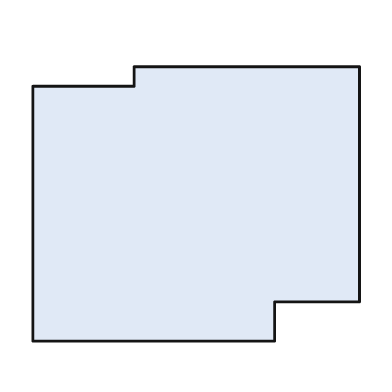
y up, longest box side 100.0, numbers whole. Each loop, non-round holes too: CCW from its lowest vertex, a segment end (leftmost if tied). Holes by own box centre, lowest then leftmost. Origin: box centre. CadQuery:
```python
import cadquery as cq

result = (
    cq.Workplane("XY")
    .moveTo(-50.0, -42.0)
    .lineTo(24.0, -42.0)
    .lineTo(24.0, -30.0)
    .lineTo(50.0, -30.0)
    .lineTo(50.0, 42.0)
    .lineTo(-19.0, 42.0)
    .lineTo(-19.0, 36.0)
    .lineTo(-50.0, 36.0)
    .close()
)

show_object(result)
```